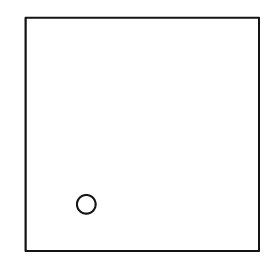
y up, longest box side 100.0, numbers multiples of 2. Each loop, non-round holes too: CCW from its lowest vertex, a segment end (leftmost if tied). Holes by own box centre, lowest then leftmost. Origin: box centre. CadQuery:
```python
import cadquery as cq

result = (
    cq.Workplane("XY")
    .moveTo(-50.0, -50.0)
    .lineTo(50.0, -50.0)
    .lineTo(50.0, 50.0)
    .lineTo(-50.0, 50.0)
    .close()
    .moveTo(-24.0, -30.0)
    .circle(4.0)
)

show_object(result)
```